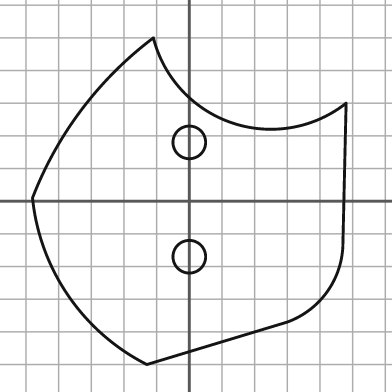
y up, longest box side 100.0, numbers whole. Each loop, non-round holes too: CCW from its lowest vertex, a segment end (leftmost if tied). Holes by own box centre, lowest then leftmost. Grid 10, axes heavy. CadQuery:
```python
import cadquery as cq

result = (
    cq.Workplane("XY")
    .moveTo(-13.0, -50.0)
    .lineTo(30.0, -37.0)
    .threePointArc((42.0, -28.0), (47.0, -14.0))
    .lineTo(48.0, 30.0)
    .threePointArc((13.0, 24.0), (-11.0, 50.0))
    .threePointArc((-33.0, 28.0), (-48.0, 1.0))
    .threePointArc((-37.0, -29.0), (-13.0, -50.0))
    .close()
    .moveTo(0.0, -17.0)
    .circle(5.0)
    .moveTo(0.0, 18.0)
    .circle(5.0)
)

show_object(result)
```